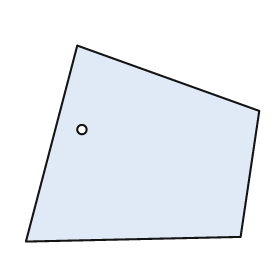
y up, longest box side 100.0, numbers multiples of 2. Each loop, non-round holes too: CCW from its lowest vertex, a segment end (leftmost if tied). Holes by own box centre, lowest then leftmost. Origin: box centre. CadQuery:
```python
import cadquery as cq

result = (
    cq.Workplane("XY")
    .moveTo(-50.0, -42.0)
    .lineTo(42.0, -40.0)
    .lineTo(50.0, 14.0)
    .lineTo(-28.0, 42.0)
    .close()
    .moveTo(-26.0, 6.0)
    .circle(2.0)
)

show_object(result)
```